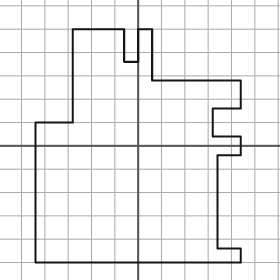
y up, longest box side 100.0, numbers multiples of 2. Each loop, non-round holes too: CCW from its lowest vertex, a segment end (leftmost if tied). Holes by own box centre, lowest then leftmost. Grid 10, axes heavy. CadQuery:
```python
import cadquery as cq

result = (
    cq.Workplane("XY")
    .moveTo(-44.0, -50.0)
    .lineTo(44.0, -50.0)
    .lineTo(44.0, -44.0)
    .lineTo(34.0, -44.0)
    .lineTo(34.0, -4.0)
    .lineTo(44.0, -4.0)
    .lineTo(44.0, 4.0)
    .lineTo(32.0, 4.0)
    .lineTo(32.0, 16.0)
    .lineTo(44.0, 16.0)
    .lineTo(44.0, 28.0)
    .lineTo(6.0, 28.0)
    .lineTo(6.0, 50.0)
    .lineTo(0.0, 50.0)
    .lineTo(0.0, 36.0)
    .lineTo(-6.0, 36.0)
    .lineTo(-6.0, 50.0)
    .lineTo(-28.0, 50.0)
    .lineTo(-28.0, 10.0)
    .lineTo(-44.0, 10.0)
    .close()
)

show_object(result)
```